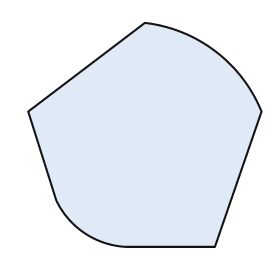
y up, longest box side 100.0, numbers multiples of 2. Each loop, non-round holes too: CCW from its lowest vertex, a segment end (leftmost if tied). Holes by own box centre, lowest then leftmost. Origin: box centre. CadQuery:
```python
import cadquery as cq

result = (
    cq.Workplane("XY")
    .moveTo(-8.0, -48.0)
    .lineTo(30.0, -48.0)
    .lineTo(50.0, 10.0)
    .threePointArc((30.0, 36.0), (0.0, 48.0))
    .lineTo(-50.0, 10.0)
    .lineTo(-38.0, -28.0)
    .threePointArc((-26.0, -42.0), (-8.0, -48.0))
    .close()
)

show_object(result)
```